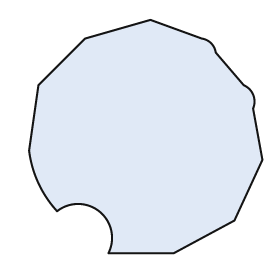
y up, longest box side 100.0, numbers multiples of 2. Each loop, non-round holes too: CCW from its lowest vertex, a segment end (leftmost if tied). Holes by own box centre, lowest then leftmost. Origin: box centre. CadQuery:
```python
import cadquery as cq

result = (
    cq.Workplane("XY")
    .moveTo(-16.0, -50.0)
    .lineTo(12.0, -50.0)
    .lineTo(38.0, -36.0)
    .lineTo(50.0, -10.0)
    .lineTo(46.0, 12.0)
    .threePointArc((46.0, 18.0), (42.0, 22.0))
    .lineTo(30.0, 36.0)
    .threePointArc((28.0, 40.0), (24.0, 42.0))
    .lineTo(2.0, 50.0)
    .lineTo(-26.0, 42.0)
    .lineTo(-46.0, 22.0)
    .lineTo(-50.0, -6.0)
    .threePointArc((-46.0, -20.0), (-38.0, -32.0))
    .threePointArc((-20.0, -32.0), (-16.0, -50.0))
    .close()
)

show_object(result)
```